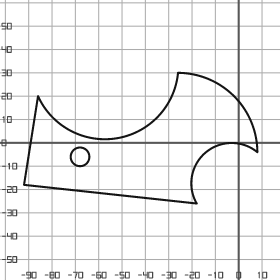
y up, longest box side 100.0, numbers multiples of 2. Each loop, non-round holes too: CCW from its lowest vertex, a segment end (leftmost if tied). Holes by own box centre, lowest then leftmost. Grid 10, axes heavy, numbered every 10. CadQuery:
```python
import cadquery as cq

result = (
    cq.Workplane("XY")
    .moveTo(-18.0, -26.0)
    .threePointArc((-14.0, -4.0), (8.0, -4.0))
    .threePointArc((-2.0, 20.0), (-26.0, 30.0))
    .threePointArc((-52.0, 2.0), (-86.0, 20.0))
    .lineTo(-92.0, -18.0)
    .close()
    .moveTo(-68.0, -6.0)
    .circle(4.0)
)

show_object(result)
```